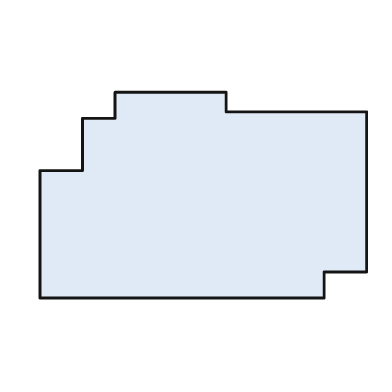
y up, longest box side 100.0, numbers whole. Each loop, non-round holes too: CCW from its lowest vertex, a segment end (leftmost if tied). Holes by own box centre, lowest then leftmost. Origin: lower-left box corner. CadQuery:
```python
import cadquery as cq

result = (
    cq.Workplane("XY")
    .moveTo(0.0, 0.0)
    .lineTo(87.0, 0.0)
    .lineTo(87.0, 8.0)
    .lineTo(100.0, 8.0)
    .lineTo(100.0, 57.0)
    .lineTo(57.0, 57.0)
    .lineTo(57.0, 63.0)
    .lineTo(23.0, 63.0)
    .lineTo(23.0, 55.0)
    .lineTo(13.0, 55.0)
    .lineTo(13.0, 39.0)
    .lineTo(0.0, 39.0)
    .close()
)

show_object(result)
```